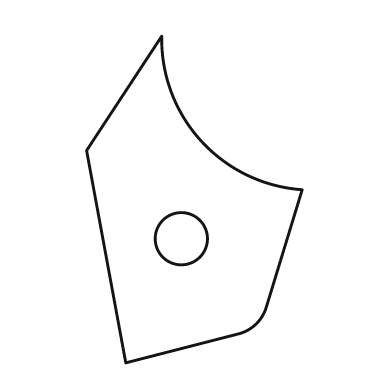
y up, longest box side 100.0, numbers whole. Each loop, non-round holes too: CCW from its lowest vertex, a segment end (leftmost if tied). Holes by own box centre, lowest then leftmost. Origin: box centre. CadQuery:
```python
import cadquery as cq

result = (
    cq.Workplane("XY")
    .moveTo(-21.0, -50.0)
    .lineTo(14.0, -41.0)
    .threePointArc((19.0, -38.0), (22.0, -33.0))
    .lineTo(33.0, 3.0)
    .threePointArc((2.0, 18.0), (-10.0, 50.0))
    .lineTo(-33.0, 15.0)
    .close()
    .moveTo(-4.0, -12.0)
    .circle(8.0)
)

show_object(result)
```